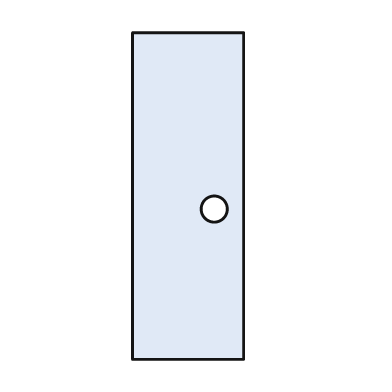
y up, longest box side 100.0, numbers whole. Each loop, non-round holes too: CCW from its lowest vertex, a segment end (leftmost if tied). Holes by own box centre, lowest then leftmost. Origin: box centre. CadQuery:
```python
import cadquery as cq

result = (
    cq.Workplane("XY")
    .moveTo(-17.0, -50.0)
    .lineTo(17.0, -50.0)
    .lineTo(17.0, 50.0)
    .lineTo(-17.0, 50.0)
    .close()
    .moveTo(8.0, -4.0)
    .circle(4.0)
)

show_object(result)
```